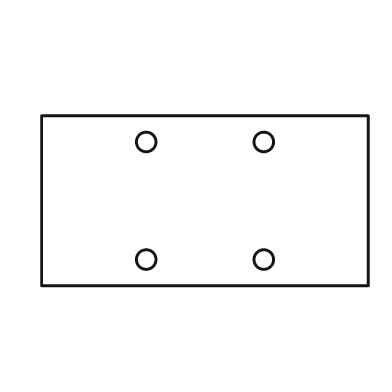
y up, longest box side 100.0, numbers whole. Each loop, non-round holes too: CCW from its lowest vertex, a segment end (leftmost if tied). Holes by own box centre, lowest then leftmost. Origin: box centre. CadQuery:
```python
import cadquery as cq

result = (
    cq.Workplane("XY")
    .moveTo(-50.0, -26.0)
    .lineTo(50.0, -26.0)
    .lineTo(50.0, 26.0)
    .lineTo(-50.0, 26.0)
    .close()
    .moveTo(-18.0, -18.0)
    .circle(3.0)
    .moveTo(18.0, -18.0)
    .circle(3.0)
    .moveTo(-18.0, 18.0)
    .circle(3.0)
    .moveTo(18.0, 18.0)
    .circle(3.0)
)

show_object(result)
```